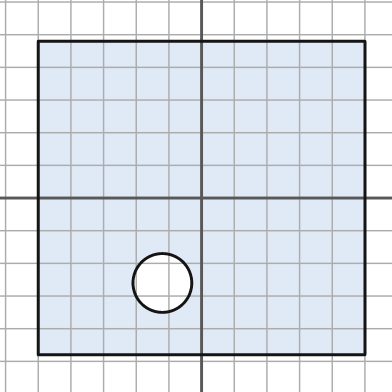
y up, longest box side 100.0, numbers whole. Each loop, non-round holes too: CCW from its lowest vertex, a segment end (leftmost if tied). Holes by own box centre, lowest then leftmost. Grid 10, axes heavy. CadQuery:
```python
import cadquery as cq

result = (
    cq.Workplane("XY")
    .moveTo(-50.0, -48.0)
    .lineTo(50.0, -48.0)
    .lineTo(50.0, 48.0)
    .lineTo(-50.0, 48.0)
    .close()
    .moveTo(-12.0, -26.0)
    .circle(9.0)
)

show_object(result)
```